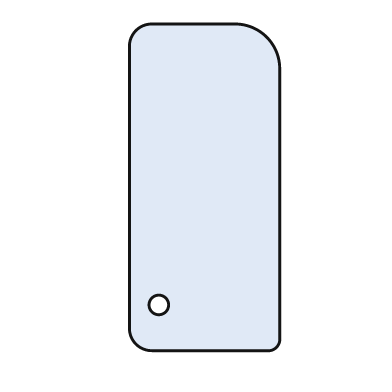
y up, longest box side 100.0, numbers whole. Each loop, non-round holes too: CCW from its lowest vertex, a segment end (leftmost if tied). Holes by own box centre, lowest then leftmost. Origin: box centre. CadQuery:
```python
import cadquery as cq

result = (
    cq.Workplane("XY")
    .moveTo(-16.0, -50.0)
    .lineTo(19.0, -50.0)
    .threePointArc((22.0, -49.0), (23.0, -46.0))
    .lineTo(23.0, 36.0)
    .threePointArc((19.0, 46.0), (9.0, 50.0))
    .lineTo(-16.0, 50.0)
    .threePointArc((-21.0, 48.0), (-23.0, 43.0))
    .lineTo(-23.0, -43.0)
    .threePointArc((-21.0, -48.0), (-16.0, -50.0))
    .close()
    .moveTo(-14.0, -36.0)
    .circle(3.0)
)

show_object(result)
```